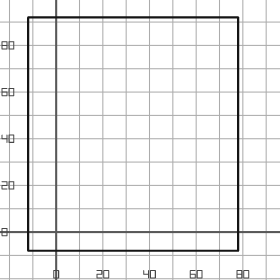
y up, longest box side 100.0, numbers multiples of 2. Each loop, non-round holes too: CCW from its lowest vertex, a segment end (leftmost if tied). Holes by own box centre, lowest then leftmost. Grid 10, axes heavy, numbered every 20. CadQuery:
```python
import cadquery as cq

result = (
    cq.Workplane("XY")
    .moveTo(-12.0, -8.0)
    .lineTo(78.0, -8.0)
    .lineTo(78.0, 92.0)
    .lineTo(-12.0, 92.0)
    .close()
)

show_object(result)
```